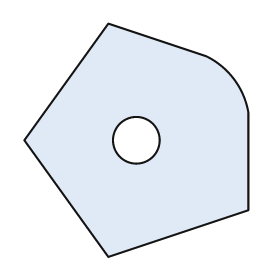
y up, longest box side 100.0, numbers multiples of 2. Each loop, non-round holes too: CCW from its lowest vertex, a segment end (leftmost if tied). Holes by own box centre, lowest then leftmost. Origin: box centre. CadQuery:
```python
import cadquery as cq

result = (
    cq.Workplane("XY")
    .moveTo(-12.0, -50.0)
    .lineTo(48.0, -30.0)
    .lineTo(48.0, 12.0)
    .threePointArc((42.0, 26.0), (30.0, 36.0))
    .lineTo(-12.0, 50.0)
    .lineTo(-48.0, 0.0)
    .close()
    .moveTo(0.0, 0.0)
    .circle(10.0)
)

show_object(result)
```